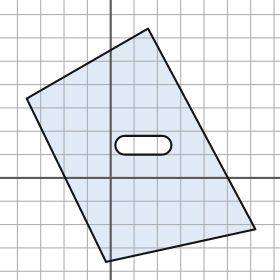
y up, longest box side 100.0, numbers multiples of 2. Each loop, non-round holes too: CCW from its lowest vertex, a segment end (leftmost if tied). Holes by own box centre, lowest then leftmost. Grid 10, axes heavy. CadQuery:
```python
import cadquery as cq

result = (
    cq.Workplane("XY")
    .moveTo(-2.0, -36.0)
    .lineTo(62.0, -22.0)
    .lineTo(16.0, 64.0)
    .lineTo(-36.0, 34.0)
    .close()
    .moveTo(6.0, 10.0)
    .lineTo(22.0, 10.0)
    .threePointArc((26.0, 14.0), (22.0, 18.0))
    .lineTo(6.0, 18.0)
    .threePointArc((2.0, 14.0), (6.0, 10.0))
    .close()
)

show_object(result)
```